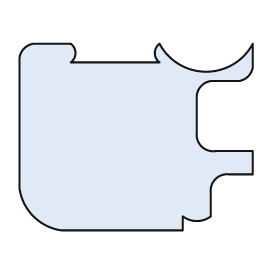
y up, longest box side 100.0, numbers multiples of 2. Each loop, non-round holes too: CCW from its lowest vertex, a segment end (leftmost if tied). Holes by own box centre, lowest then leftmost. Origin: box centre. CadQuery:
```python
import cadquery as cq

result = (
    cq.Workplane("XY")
    .moveTo(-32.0, -40.0)
    .lineTo(20.0, -40.0)
    .lineTo(20.0, -34.0)
    .threePointArc((26.0, -36.0), (32.0, -34.0))
    .lineTo(32.0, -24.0)
    .threePointArc((34.0, -18.0), (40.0, -16.0))
    .lineTo(50.0, -16.0)
    .lineTo(50.0, -6.0)
    .lineTo(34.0, -6.0)
    .threePointArc((28.0, -4.0), (26.0, 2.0))
    .lineTo(26.0, 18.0)
    .threePointArc((28.0, 22.0), (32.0, 24.0))
    .lineTo(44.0, 24.0)
    .threePointArc((48.0, 26.0), (50.0, 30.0))
    .lineTo(50.0, 40.0)
    .threePointArc((30.0, 28.0), (10.0, 40.0))
    .threePointArc((8.0, 36.0), (10.0, 32.0))
    .lineTo(-28.0, 32.0)
    .threePointArc((-26.0, 36.0), (-28.0, 40.0))
    .lineTo(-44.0, 40.0)
    .threePointArc((-48.0, 38.0), (-50.0, 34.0))
    .lineTo(-50.0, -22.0)
    .threePointArc((-44.0, -34.0), (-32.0, -40.0))
    .close()
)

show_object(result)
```